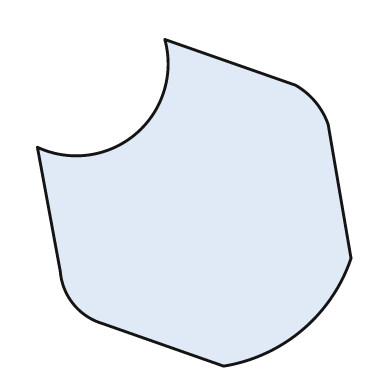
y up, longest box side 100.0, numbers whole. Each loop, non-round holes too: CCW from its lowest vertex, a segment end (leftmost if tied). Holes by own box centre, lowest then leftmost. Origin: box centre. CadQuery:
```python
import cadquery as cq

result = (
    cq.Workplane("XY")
    .moveTo(9.0, -50.0)
    .threePointArc((33.0, -39.0), (48.0, -17.0))
    .lineTo(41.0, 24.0)
    .threePointArc((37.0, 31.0), (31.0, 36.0))
    .lineTo(-9.0, 50.0)
    .threePointArc((-18.0, 21.0), (-48.0, 17.0))
    .lineTo(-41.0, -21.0)
    .threePointArc((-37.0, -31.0), (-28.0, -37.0))
    .close()
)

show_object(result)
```